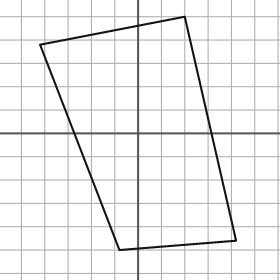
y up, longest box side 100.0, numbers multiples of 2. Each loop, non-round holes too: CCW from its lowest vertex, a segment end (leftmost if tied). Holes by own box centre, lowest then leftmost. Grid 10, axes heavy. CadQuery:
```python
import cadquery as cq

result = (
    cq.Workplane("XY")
    .moveTo(-8.0, -50.0)
    .lineTo(42.0, -46.0)
    .lineTo(20.0, 50.0)
    .lineTo(-42.0, 38.0)
    .close()
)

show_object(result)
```